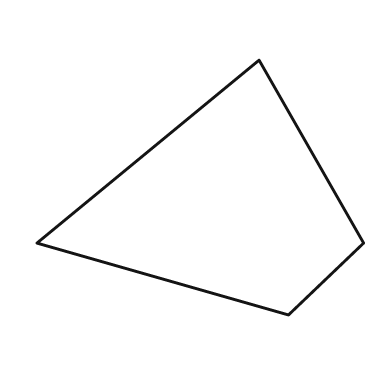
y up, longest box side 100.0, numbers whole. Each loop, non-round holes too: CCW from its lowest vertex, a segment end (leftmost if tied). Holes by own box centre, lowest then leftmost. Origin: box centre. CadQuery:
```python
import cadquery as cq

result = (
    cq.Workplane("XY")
    .moveTo(27.0, -39.0)
    .lineTo(50.0, -17.0)
    .lineTo(18.0, 39.0)
    .lineTo(-50.0, -17.0)
    .close()
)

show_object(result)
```